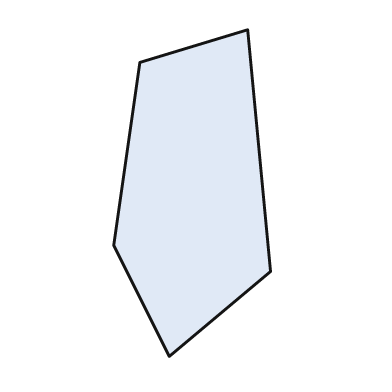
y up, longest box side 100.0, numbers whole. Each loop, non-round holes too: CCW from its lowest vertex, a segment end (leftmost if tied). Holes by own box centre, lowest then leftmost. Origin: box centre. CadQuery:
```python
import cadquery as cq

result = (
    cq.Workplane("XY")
    .moveTo(-7.0, -50.0)
    .lineTo(24.0, -24.0)
    .lineTo(17.0, 50.0)
    .lineTo(-16.0, 40.0)
    .lineTo(-24.0, -16.0)
    .close()
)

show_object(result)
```